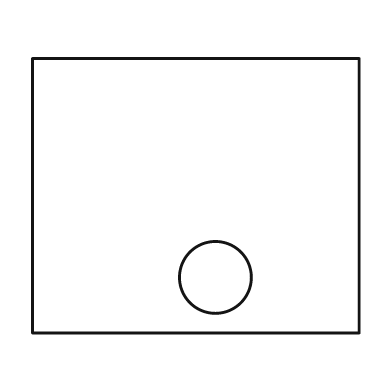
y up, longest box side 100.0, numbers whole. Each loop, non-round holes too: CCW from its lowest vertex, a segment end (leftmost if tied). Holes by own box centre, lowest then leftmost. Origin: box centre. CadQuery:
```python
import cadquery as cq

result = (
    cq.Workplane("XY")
    .moveTo(-50.0, -42.0)
    .lineTo(50.0, -42.0)
    .lineTo(50.0, 42.0)
    .lineTo(-50.0, 42.0)
    .close()
    .moveTo(6.0, -25.0)
    .circle(11.0)
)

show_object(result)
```